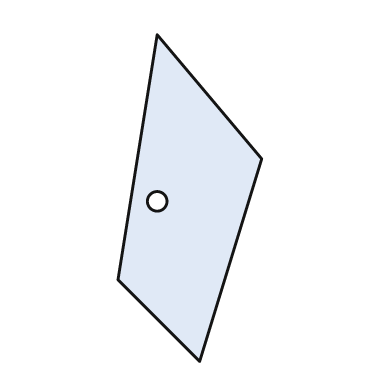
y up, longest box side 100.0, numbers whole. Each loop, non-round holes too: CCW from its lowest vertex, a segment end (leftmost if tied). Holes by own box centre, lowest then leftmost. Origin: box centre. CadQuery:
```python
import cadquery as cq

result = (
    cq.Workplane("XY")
    .moveTo(3.0, -50.0)
    .lineTo(22.0, 12.0)
    .lineTo(-10.0, 50.0)
    .lineTo(-22.0, -25.0)
    .close()
    .moveTo(-10.0, -1.0)
    .circle(3.0)
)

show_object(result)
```